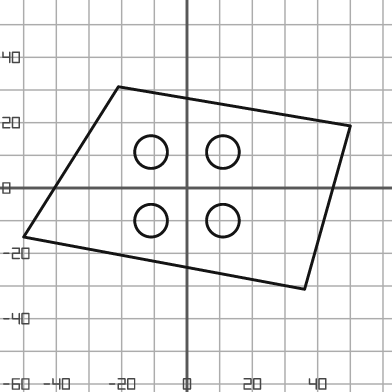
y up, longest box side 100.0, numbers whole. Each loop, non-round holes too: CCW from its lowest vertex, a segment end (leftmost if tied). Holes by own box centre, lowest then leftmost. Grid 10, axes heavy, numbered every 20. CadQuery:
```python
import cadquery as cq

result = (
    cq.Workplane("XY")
    .moveTo(36.0, -31.0)
    .lineTo(50.0, 19.0)
    .lineTo(-21.0, 31.0)
    .lineTo(-50.0, -15.0)
    .close()
    .moveTo(-11.0, -10.0)
    .circle(5.0)
    .moveTo(11.0, -10.0)
    .circle(5.0)
    .moveTo(-11.0, 11.0)
    .circle(5.0)
    .moveTo(11.0, 11.0)
    .circle(5.0)
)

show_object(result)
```